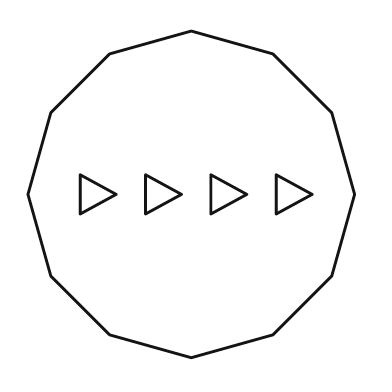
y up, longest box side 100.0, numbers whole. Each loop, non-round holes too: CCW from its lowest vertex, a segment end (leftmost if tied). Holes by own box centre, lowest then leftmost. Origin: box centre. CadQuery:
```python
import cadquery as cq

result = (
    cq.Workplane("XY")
    .moveTo(0.0, -50.0)
    .lineTo(25.0, -43.0)
    .lineTo(43.0, -25.0)
    .lineTo(50.0, 0.0)
    .lineTo(43.0, 25.0)
    .lineTo(25.0, 43.0)
    .lineTo(0.0, 50.0)
    .lineTo(-25.0, 43.0)
    .lineTo(-43.0, 25.0)
    .lineTo(-50.0, 0.0)
    .lineTo(-43.0, -25.0)
    .lineTo(-25.0, -43.0)
    .close()
    .moveTo(-34.0, -6.0)
    .lineTo(-23.0, 0.0)
    .lineTo(-34.0, 6.0)
    .close()
    .moveTo(-14.0, -6.0)
    .lineTo(-3.0, 0.0)
    .lineTo(-14.0, 6.0)
    .close()
    .moveTo(6.0, -6.0)
    .lineTo(17.0, 0.0)
    .lineTo(6.0, 6.0)
    .close()
    .moveTo(26.0, -6.0)
    .lineTo(37.0, 0.0)
    .lineTo(26.0, 6.0)
    .close()
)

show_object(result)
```